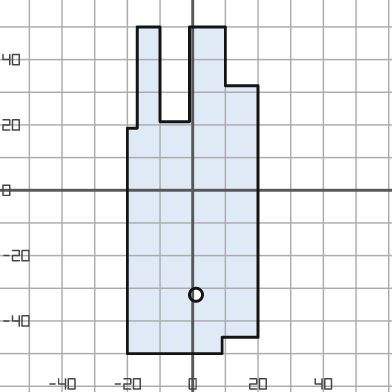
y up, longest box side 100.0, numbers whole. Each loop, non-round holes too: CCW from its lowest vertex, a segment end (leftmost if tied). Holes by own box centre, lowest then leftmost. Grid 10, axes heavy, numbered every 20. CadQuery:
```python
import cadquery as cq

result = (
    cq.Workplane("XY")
    .moveTo(-20.0, -50.0)
    .lineTo(9.0, -50.0)
    .lineTo(9.0, -45.0)
    .lineTo(20.0, -45.0)
    .lineTo(20.0, 32.0)
    .lineTo(10.0, 32.0)
    .lineTo(10.0, 50.0)
    .lineTo(-1.0, 50.0)
    .lineTo(-1.0, 21.0)
    .lineTo(-10.0, 21.0)
    .lineTo(-10.0, 50.0)
    .lineTo(-17.0, 50.0)
    .lineTo(-17.0, 19.0)
    .lineTo(-20.0, 19.0)
    .close()
    .moveTo(1.0, -32.0)
    .circle(2.0)
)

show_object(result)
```